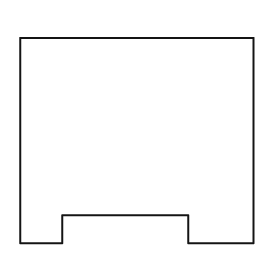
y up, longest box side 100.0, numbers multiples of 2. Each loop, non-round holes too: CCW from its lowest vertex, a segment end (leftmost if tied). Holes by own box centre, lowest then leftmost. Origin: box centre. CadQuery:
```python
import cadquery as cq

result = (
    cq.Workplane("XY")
    .moveTo(-50.0, -44.0)
    .lineTo(-32.0, -44.0)
    .lineTo(-32.0, -32.0)
    .lineTo(22.0, -32.0)
    .lineTo(22.0, -44.0)
    .lineTo(50.0, -44.0)
    .lineTo(50.0, 44.0)
    .lineTo(-50.0, 44.0)
    .close()
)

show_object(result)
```